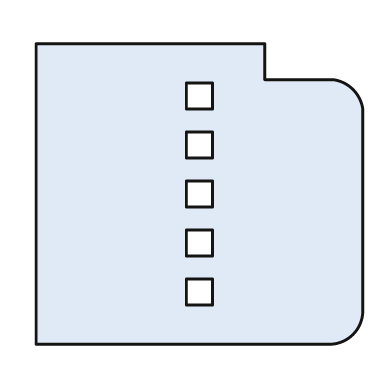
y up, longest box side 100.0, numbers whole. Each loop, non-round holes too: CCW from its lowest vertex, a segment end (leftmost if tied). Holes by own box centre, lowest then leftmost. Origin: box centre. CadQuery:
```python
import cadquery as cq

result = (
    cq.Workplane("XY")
    .moveTo(-50.0, -46.0)
    .lineTo(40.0, -46.0)
    .threePointArc((47.0, -43.0), (50.0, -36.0))
    .lineTo(50.0, 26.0)
    .threePointArc((47.0, 32.0), (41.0, 35.0))
    .lineTo(20.0, 35.0)
    .lineTo(20.0, 46.0)
    .lineTo(-50.0, 46.0)
    .close()
    .moveTo(-4.0, -34.0)
    .lineTo(4.0, -34.0)
    .lineTo(4.0, -26.0)
    .lineTo(-4.0, -26.0)
    .close()
    .moveTo(-4.0, -19.0)
    .lineTo(4.0, -19.0)
    .lineTo(4.0, -11.0)
    .lineTo(-4.0, -11.0)
    .close()
    .moveTo(-4.0, -4.0)
    .lineTo(4.0, -4.0)
    .lineTo(4.0, 4.0)
    .lineTo(-4.0, 4.0)
    .close()
    .moveTo(-4.0, 11.0)
    .lineTo(4.0, 11.0)
    .lineTo(4.0, 19.0)
    .lineTo(-4.0, 19.0)
    .close()
    .moveTo(-4.0, 26.0)
    .lineTo(4.0, 26.0)
    .lineTo(4.0, 34.0)
    .lineTo(-4.0, 34.0)
    .close()
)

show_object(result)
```